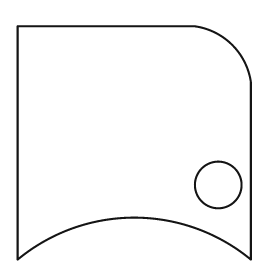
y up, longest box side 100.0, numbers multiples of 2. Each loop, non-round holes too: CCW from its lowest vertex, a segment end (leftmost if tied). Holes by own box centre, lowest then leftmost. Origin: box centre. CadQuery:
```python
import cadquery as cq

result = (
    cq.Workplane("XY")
    .moveTo(-50.0, -50.0)
    .threePointArc((0.0, -32.0), (50.0, -50.0))
    .lineTo(50.0, 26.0)
    .threePointArc((42.0, 42.0), (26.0, 50.0))
    .lineTo(-50.0, 50.0)
    .close()
    .moveTo(36.0, -18.0)
    .circle(10.0)
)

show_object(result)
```